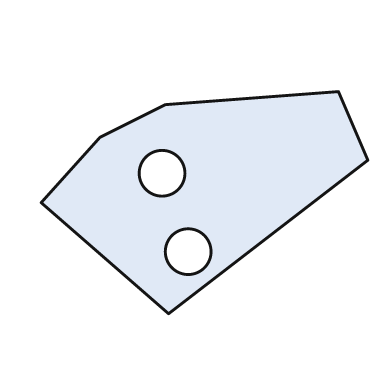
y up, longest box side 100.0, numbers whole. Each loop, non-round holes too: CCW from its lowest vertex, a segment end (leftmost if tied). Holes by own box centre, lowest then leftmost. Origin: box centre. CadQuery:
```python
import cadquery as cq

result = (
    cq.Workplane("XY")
    .moveTo(-11.0, -34.0)
    .lineTo(50.0, 13.0)
    .lineTo(41.0, 34.0)
    .lineTo(-12.0, 30.0)
    .lineTo(-32.0, 20.0)
    .lineTo(-50.0, 0.0)
    .close()
    .moveTo(-5.0, -15.0)
    .circle(7.0)
    .moveTo(-13.0, 9.0)
    .circle(7.0)
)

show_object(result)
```